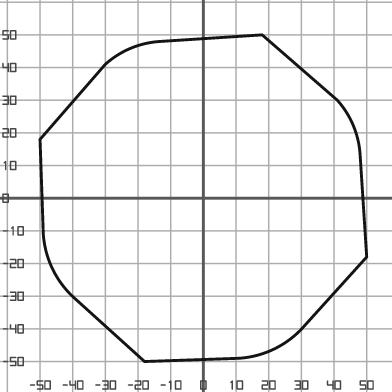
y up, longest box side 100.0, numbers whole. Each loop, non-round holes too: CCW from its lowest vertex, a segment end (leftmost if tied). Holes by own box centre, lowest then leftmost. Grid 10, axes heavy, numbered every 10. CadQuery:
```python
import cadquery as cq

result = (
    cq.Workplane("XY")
    .moveTo(-18.0, -50.0)
    .lineTo(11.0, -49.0)
    .threePointArc((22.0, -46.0), (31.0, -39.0))
    .lineTo(50.0, -18.0)
    .lineTo(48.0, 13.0)
    .threePointArc((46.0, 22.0), (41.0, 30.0))
    .lineTo(18.0, 50.0)
    .lineTo(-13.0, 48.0)
    .threePointArc((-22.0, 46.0), (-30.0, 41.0))
    .lineTo(-50.0, 18.0)
    .lineTo(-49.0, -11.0)
    .threePointArc((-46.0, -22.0), (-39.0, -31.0))
    .close()
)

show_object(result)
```